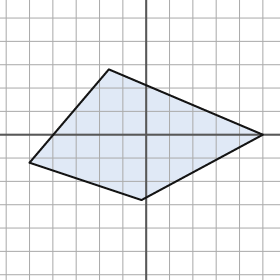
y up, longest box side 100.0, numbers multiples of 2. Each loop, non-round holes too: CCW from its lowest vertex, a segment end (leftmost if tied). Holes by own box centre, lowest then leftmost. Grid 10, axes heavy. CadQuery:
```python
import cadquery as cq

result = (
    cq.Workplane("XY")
    .moveTo(-2.0, -28.0)
    .lineTo(50.0, 0.0)
    .lineTo(-16.0, 28.0)
    .lineTo(-50.0, -12.0)
    .close()
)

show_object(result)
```